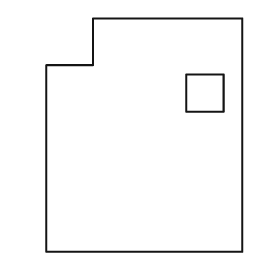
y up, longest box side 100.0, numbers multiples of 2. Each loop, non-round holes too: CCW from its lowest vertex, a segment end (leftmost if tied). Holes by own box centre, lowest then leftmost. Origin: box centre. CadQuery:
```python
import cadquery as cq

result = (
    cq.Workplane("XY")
    .moveTo(-42.0, -50.0)
    .lineTo(42.0, -50.0)
    .lineTo(42.0, 50.0)
    .lineTo(-22.0, 50.0)
    .lineTo(-22.0, 30.0)
    .lineTo(-42.0, 30.0)
    .close()
    .moveTo(18.0, 10.0)
    .lineTo(34.0, 10.0)
    .lineTo(34.0, 26.0)
    .lineTo(18.0, 26.0)
    .close()
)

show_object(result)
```